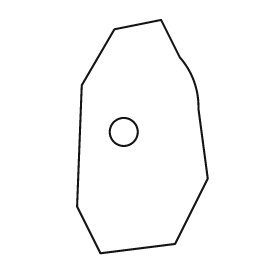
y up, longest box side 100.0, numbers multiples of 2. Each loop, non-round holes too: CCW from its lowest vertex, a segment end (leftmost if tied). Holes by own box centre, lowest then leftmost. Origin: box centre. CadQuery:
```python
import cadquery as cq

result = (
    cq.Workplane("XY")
    .moveTo(-18.0, -50.0)
    .lineTo(14.0, -46.0)
    .lineTo(28.0, -18.0)
    .lineTo(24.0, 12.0)
    .threePointArc((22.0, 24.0), (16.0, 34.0))
    .lineTo(8.0, 50.0)
    .lineTo(-12.0, 46.0)
    .lineTo(-26.0, 22.0)
    .lineTo(-28.0, -30.0)
    .close()
    .moveTo(-8.0, 2.0)
    .circle(6.0)
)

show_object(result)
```